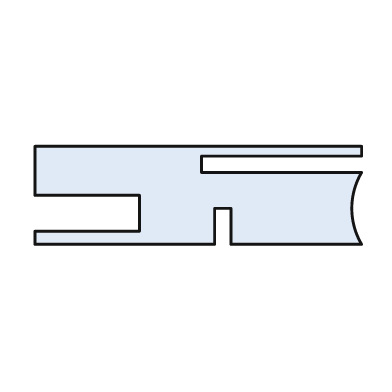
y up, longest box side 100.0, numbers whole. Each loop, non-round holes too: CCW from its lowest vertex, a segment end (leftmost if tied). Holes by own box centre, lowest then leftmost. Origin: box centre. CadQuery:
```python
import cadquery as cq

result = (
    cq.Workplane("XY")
    .moveTo(-50.0, -15.0)
    .lineTo(5.0, -15.0)
    .lineTo(5.0, -4.0)
    .lineTo(10.0, -4.0)
    .lineTo(10.0, -15.0)
    .lineTo(50.0, -15.0)
    .threePointArc((47.0, -4.0), (50.0, 7.0))
    .lineTo(1.0, 7.0)
    .lineTo(1.0, 12.0)
    .lineTo(50.0, 12.0)
    .lineTo(50.0, 15.0)
    .lineTo(-50.0, 15.0)
    .lineTo(-50.0, 0.0)
    .lineTo(-18.0, 0.0)
    .lineTo(-18.0, -11.0)
    .lineTo(-50.0, -11.0)
    .close()
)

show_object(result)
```